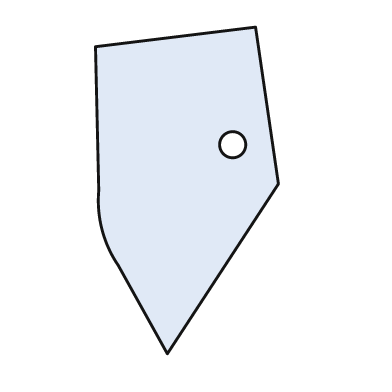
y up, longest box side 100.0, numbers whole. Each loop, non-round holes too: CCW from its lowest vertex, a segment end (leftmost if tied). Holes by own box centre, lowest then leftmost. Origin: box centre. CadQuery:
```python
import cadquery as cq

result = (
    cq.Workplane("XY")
    .moveTo(-6.0, -50.0)
    .lineTo(28.0, 2.0)
    .lineTo(21.0, 50.0)
    .lineTo(-28.0, 44.0)
    .lineTo(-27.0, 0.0)
    .threePointArc((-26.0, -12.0), (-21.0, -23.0))
    .close()
    .moveTo(14.0, 14.0)
    .circle(4.0)
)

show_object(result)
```